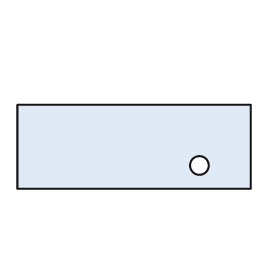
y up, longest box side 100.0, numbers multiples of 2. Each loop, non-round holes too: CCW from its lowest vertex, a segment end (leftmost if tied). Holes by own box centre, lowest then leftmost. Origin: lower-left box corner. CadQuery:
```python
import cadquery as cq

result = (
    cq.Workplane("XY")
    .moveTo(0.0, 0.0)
    .lineTo(100.0, 0.0)
    .lineTo(100.0, 36.0)
    .lineTo(0.0, 36.0)
    .close()
    .moveTo(78.0, 10.0)
    .circle(4.0)
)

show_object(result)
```